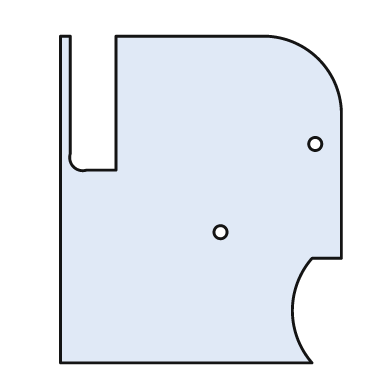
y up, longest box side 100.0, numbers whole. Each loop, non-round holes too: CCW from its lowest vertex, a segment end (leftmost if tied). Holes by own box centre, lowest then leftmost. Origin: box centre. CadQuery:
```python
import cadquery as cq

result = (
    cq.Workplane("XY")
    .moveTo(-43.0, -50.0)
    .lineTo(34.0, -50.0)
    .threePointArc((28.0, -34.0), (34.0, -18.0))
    .lineTo(43.0, -18.0)
    .lineTo(43.0, 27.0)
    .threePointArc((36.0, 43.0), (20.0, 50.0))
    .lineTo(-26.0, 50.0)
    .lineTo(-26.0, 9.0)
    .lineTo(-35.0, 9.0)
    .threePointArc((-39.0, 10.0), (-40.0, 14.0))
    .lineTo(-40.0, 50.0)
    .lineTo(-43.0, 50.0)
    .close()
    .moveTo(6.0, -10.0)
    .circle(2.0)
    .moveTo(35.0, 17.0)
    .circle(2.0)
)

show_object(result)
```